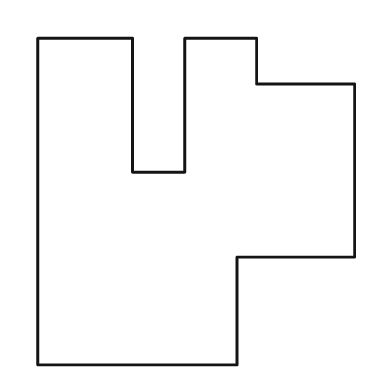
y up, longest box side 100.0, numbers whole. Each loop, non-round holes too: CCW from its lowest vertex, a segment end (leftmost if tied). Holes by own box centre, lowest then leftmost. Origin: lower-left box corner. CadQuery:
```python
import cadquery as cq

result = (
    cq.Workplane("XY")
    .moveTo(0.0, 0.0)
    .lineTo(61.0, 0.0)
    .lineTo(61.0, 33.0)
    .lineTo(97.0, 33.0)
    .lineTo(97.0, 86.0)
    .lineTo(67.0, 86.0)
    .lineTo(67.0, 100.0)
    .lineTo(45.0, 100.0)
    .lineTo(45.0, 59.0)
    .lineTo(29.0, 59.0)
    .lineTo(29.0, 100.0)
    .lineTo(0.0, 100.0)
    .close()
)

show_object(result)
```